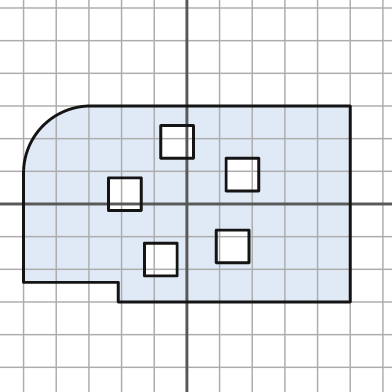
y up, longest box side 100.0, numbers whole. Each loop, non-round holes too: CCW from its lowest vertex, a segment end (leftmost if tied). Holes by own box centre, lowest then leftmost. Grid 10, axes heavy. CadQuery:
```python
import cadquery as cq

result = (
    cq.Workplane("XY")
    .moveTo(-21.0, -30.0)
    .lineTo(50.0, -30.0)
    .lineTo(50.0, 30.0)
    .lineTo(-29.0, 30.0)
    .threePointArc((-44.0, 24.0), (-50.0, 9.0))
    .lineTo(-50.0, -24.0)
    .lineTo(-21.0, -24.0)
    .close()
    .moveTo(-13.0, -22.0)
    .lineTo(-3.0, -22.0)
    .lineTo(-3.0, -12.0)
    .lineTo(-13.0, -12.0)
    .close()
    .moveTo(9.0, -18.0)
    .lineTo(19.0, -18.0)
    .lineTo(19.0, -8.0)
    .lineTo(9.0, -8.0)
    .close()
    .moveTo(-24.0, -2.0)
    .lineTo(-14.0, -2.0)
    .lineTo(-14.0, 8.0)
    .lineTo(-24.0, 8.0)
    .close()
    .moveTo(12.0, 4.0)
    .lineTo(22.0, 4.0)
    .lineTo(22.0, 14.0)
    .lineTo(12.0, 14.0)
    .close()
    .moveTo(-8.0, 14.0)
    .lineTo(2.0, 14.0)
    .lineTo(2.0, 24.0)
    .lineTo(-8.0, 24.0)
    .close()
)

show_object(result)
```